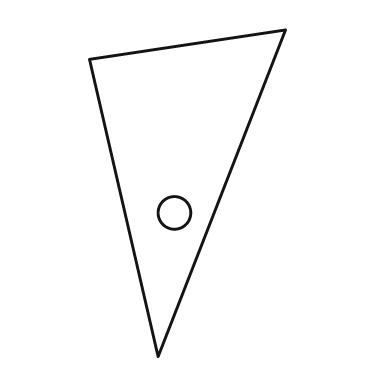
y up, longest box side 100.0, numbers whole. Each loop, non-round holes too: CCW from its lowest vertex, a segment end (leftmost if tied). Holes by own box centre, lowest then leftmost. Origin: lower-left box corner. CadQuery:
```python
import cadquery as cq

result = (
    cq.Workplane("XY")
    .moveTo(21.0, 0.0)
    .lineTo(60.0, 100.0)
    .lineTo(0.0, 91.0)
    .close()
    .moveTo(26.0, 44.0)
    .circle(5.0)
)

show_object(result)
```